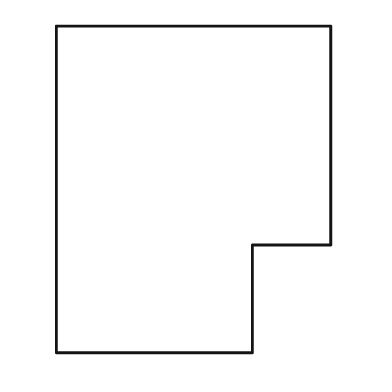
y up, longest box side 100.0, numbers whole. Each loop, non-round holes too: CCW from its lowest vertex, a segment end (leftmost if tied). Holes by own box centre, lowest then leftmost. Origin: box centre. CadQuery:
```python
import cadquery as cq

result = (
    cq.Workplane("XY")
    .moveTo(-42.0, -50.0)
    .lineTo(18.0, -50.0)
    .lineTo(18.0, -17.0)
    .lineTo(42.0, -17.0)
    .lineTo(42.0, 50.0)
    .lineTo(-42.0, 50.0)
    .close()
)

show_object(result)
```